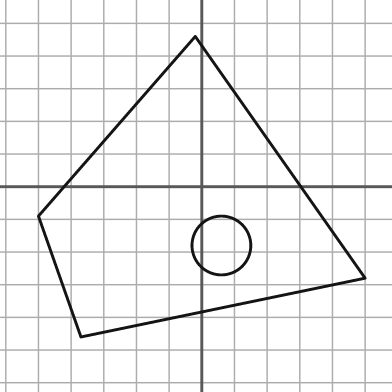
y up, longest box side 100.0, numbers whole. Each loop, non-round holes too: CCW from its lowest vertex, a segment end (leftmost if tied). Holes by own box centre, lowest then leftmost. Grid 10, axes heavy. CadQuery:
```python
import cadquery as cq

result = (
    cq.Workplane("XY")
    .moveTo(-37.0, -46.0)
    .lineTo(50.0, -28.0)
    .lineTo(-2.0, 46.0)
    .lineTo(-50.0, -9.0)
    .close()
    .moveTo(6.0, -18.0)
    .circle(9.0)
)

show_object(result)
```